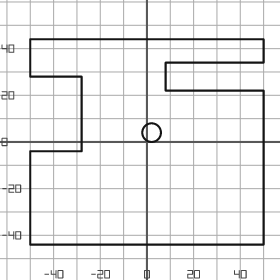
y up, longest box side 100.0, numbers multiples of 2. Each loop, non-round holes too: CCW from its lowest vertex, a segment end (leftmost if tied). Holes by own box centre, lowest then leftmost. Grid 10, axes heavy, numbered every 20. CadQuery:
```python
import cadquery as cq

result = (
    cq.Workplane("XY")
    .moveTo(-50.0, -44.0)
    .lineTo(50.0, -44.0)
    .lineTo(50.0, 22.0)
    .lineTo(8.0, 22.0)
    .lineTo(8.0, 34.0)
    .lineTo(50.0, 34.0)
    .lineTo(50.0, 44.0)
    .lineTo(-50.0, 44.0)
    .lineTo(-50.0, 28.0)
    .lineTo(-28.0, 28.0)
    .lineTo(-28.0, -4.0)
    .lineTo(-50.0, -4.0)
    .close()
    .moveTo(2.0, 4.0)
    .circle(4.0)
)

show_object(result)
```